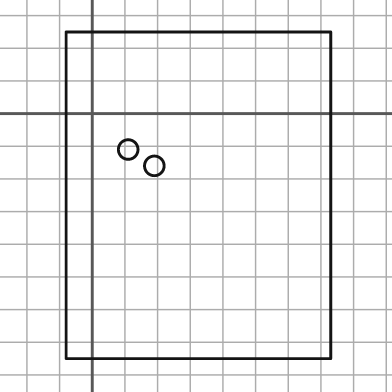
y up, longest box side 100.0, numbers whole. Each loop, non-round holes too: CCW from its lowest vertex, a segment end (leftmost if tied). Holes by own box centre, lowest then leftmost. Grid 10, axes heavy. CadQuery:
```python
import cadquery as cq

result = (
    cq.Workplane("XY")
    .moveTo(-8.0, -75.0)
    .lineTo(73.0, -75.0)
    .lineTo(73.0, 25.0)
    .lineTo(-8.0, 25.0)
    .close()
    .moveTo(19.0, -16.0)
    .circle(3.0)
    .moveTo(11.0, -11.0)
    .circle(3.0)
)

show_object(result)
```